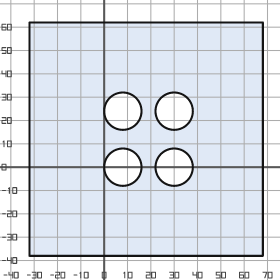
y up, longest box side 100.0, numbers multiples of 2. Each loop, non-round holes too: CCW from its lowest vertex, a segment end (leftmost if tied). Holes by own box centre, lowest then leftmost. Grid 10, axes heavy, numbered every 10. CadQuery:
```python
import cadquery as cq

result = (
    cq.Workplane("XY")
    .moveTo(-32.0, -38.0)
    .lineTo(68.0, -38.0)
    .lineTo(68.0, 62.0)
    .lineTo(-32.0, 62.0)
    .close()
    .moveTo(8.0, 0.0)
    .circle(8.0)
    .moveTo(30.0, 0.0)
    .circle(8.0)
    .moveTo(8.0, 24.0)
    .circle(8.0)
    .moveTo(30.0, 24.0)
    .circle(8.0)
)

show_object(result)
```